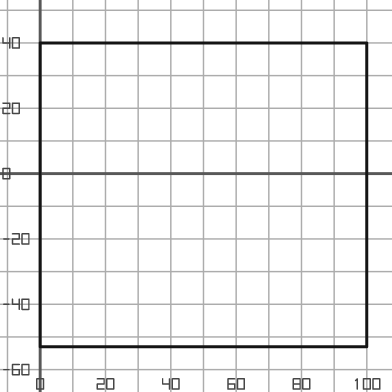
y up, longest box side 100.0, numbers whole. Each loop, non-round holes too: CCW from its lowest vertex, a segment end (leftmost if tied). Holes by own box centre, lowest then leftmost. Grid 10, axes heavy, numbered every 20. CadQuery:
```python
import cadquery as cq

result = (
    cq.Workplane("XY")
    .moveTo(0.0, -53.0)
    .lineTo(100.0, -53.0)
    .lineTo(100.0, 40.0)
    .lineTo(0.0, 40.0)
    .close()
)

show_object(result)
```